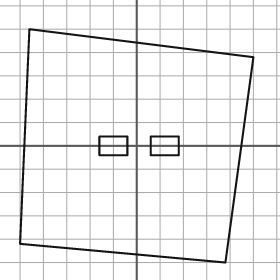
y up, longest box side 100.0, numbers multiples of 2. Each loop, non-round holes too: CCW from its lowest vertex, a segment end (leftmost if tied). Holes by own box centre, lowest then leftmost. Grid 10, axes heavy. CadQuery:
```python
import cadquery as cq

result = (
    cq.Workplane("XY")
    .moveTo(38.0, -50.0)
    .lineTo(50.0, 38.0)
    .lineTo(-46.0, 50.0)
    .lineTo(-50.0, -42.0)
    .close()
    .moveTo(-16.0, -4.0)
    .lineTo(-4.0, -4.0)
    .lineTo(-4.0, 4.0)
    .lineTo(-16.0, 4.0)
    .close()
    .moveTo(6.0, -4.0)
    .lineTo(18.0, -4.0)
    .lineTo(18.0, 4.0)
    .lineTo(6.0, 4.0)
    .close()
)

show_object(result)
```